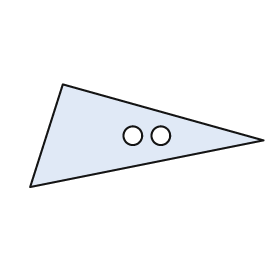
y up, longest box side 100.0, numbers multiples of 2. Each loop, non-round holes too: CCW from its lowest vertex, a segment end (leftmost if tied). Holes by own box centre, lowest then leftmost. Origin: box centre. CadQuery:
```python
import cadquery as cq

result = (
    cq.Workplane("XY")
    .moveTo(-50.0, -22.0)
    .lineTo(50.0, -2.0)
    .lineTo(-36.0, 22.0)
    .close()
    .moveTo(-6.0, 0.0)
    .circle(4.0)
    .moveTo(6.0, 0.0)
    .circle(4.0)
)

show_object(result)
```